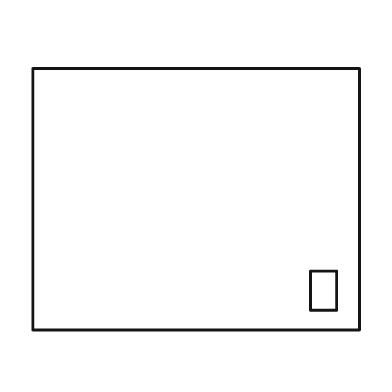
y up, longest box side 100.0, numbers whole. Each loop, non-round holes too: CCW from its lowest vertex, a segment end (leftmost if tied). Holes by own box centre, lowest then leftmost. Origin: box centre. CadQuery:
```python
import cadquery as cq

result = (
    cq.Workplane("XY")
    .moveTo(-50.0, -40.0)
    .lineTo(50.0, -40.0)
    .lineTo(50.0, 40.0)
    .lineTo(-50.0, 40.0)
    .close()
    .moveTo(35.0, -34.0)
    .lineTo(43.0, -34.0)
    .lineTo(43.0, -22.0)
    .lineTo(35.0, -22.0)
    .close()
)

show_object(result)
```